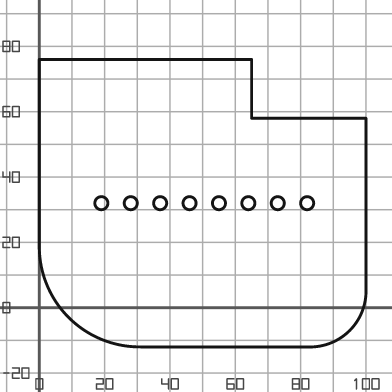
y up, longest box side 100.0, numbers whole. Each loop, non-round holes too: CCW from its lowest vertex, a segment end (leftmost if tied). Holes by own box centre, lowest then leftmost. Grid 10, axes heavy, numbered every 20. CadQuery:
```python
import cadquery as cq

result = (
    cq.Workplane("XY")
    .moveTo(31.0, -12.0)
    .lineTo(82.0, -12.0)
    .threePointArc((95.0, -7.0), (100.0, 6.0))
    .lineTo(100.0, 58.0)
    .lineTo(65.0, 58.0)
    .lineTo(65.0, 76.0)
    .lineTo(0.0, 76.0)
    .lineTo(0.0, 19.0)
    .threePointArc((9.0, -3.0), (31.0, -12.0))
    .close()
    .moveTo(19.0, 32.0)
    .circle(2.0)
    .moveTo(28.0, 32.0)
    .circle(2.0)
    .moveTo(37.0, 32.0)
    .circle(2.0)
    .moveTo(46.0, 32.0)
    .circle(2.0)
    .moveTo(55.0, 32.0)
    .circle(2.0)
    .moveTo(64.0, 32.0)
    .circle(2.0)
    .moveTo(73.0, 32.0)
    .circle(2.0)
    .moveTo(82.0, 32.0)
    .circle(2.0)
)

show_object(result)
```